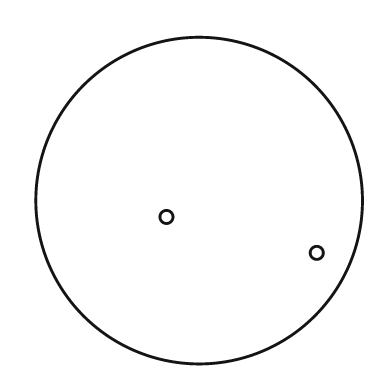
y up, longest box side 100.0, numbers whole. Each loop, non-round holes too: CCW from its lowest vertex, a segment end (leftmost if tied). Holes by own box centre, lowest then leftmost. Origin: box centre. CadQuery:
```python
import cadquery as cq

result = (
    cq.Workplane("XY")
    .moveTo(0.0, 0.0)
    .circle(50.0)
    .moveTo(36.0, -16.0)
    .circle(2.0)
    .moveTo(-10.0, -5.0)
    .circle(2.0)
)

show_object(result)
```